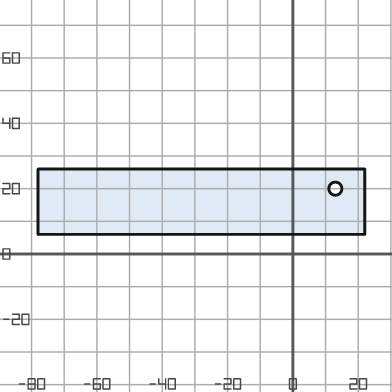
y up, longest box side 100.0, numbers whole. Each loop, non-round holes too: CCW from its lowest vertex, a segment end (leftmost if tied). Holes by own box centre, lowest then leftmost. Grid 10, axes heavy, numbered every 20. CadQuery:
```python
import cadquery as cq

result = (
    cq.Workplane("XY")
    .moveTo(-78.0, 6.0)
    .lineTo(22.0, 6.0)
    .lineTo(22.0, 26.0)
    .lineTo(-78.0, 26.0)
    .close()
    .moveTo(13.0, 20.0)
    .circle(2.0)
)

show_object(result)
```